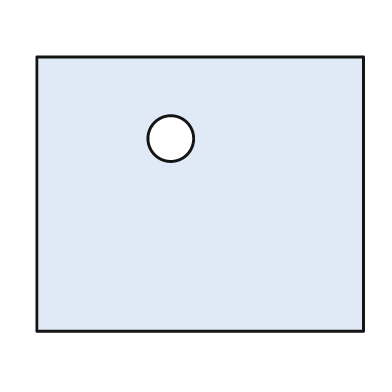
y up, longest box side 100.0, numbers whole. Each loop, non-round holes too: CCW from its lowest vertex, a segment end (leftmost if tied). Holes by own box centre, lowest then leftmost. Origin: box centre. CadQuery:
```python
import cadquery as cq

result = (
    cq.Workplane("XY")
    .moveTo(-50.0, -42.0)
    .lineTo(50.0, -42.0)
    .lineTo(50.0, 42.0)
    .lineTo(-50.0, 42.0)
    .close()
    .moveTo(-9.0, 17.0)
    .circle(7.0)
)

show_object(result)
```